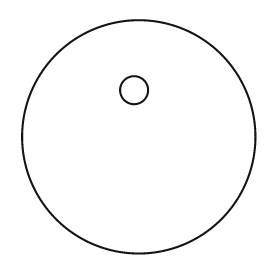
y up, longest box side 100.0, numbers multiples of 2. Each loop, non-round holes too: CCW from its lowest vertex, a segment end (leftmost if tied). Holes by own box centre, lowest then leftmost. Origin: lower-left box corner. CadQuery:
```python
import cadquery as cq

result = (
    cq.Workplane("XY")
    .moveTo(50.0, 50.0)
    .circle(50.0)
    .moveTo(48.0, 70.0)
    .circle(6.0)
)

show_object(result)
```